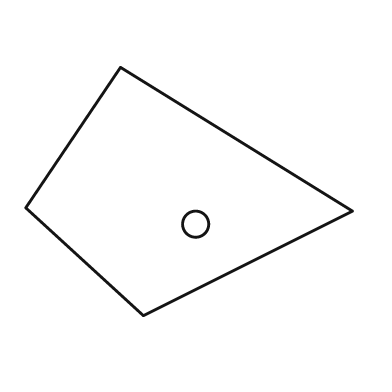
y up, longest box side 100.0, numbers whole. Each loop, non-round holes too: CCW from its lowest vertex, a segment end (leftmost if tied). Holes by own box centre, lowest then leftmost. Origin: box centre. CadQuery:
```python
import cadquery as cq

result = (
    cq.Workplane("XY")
    .moveTo(-14.0, -38.0)
    .lineTo(50.0, -6.0)
    .lineTo(-21.0, 38.0)
    .lineTo(-50.0, -5.0)
    .close()
    .moveTo(2.0, -10.0)
    .circle(4.0)
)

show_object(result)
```